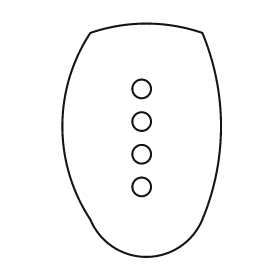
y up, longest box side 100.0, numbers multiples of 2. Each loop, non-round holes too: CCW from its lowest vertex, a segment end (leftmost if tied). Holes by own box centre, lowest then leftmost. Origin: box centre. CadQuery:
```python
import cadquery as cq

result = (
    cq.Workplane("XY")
    .moveTo(-22.0, -34.0)
    .threePointArc((2.0, -50.0), (26.0, -34.0))
    .threePointArc((34.0, 6.0), (26.0, 46.0))
    .threePointArc((2.0, 50.0), (-22.0, 46.0))
    .threePointArc((-34.0, 6.0), (-22.0, -34.0))
    .close()
    .moveTo(0.0, -20.0)
    .circle(4.0)
    .moveTo(0.0, -6.0)
    .circle(4.0)
    .moveTo(0.0, 8.0)
    .circle(4.0)
    .moveTo(0.0, 22.0)
    .circle(4.0)
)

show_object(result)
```